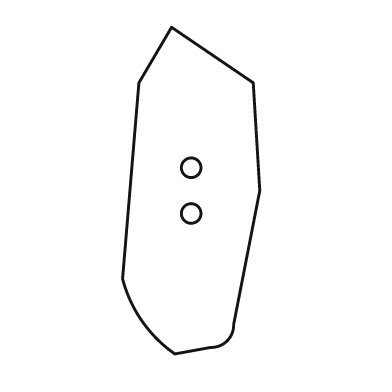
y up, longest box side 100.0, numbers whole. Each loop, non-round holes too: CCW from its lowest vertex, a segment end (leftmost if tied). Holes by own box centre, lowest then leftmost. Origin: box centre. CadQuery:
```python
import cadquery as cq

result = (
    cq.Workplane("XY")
    .moveTo(-5.0, -50.0)
    .lineTo(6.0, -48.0)
    .threePointArc((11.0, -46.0), (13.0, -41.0))
    .lineTo(21.0, 0.0)
    .lineTo(19.0, 33.0)
    .lineTo(-6.0, 50.0)
    .lineTo(-16.0, 33.0)
    .lineTo(-21.0, -27.0)
    .threePointArc((-15.0, -40.0), (-5.0, -50.0))
    .close()
    .moveTo(0.0, -7.0)
    .circle(3.0)
    .moveTo(0.0, 7.0)
    .circle(3.0)
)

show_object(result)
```